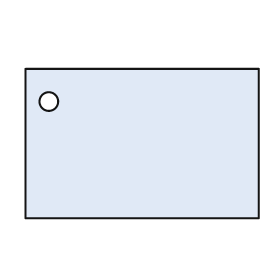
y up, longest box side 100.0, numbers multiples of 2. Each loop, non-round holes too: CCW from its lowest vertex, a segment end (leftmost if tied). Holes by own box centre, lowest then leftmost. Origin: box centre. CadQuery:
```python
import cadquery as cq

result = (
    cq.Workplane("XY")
    .moveTo(-50.0, -32.0)
    .lineTo(50.0, -32.0)
    .lineTo(50.0, 32.0)
    .lineTo(-50.0, 32.0)
    .close()
    .moveTo(-40.0, 18.0)
    .circle(4.0)
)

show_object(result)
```